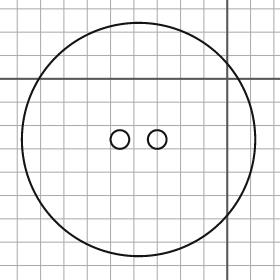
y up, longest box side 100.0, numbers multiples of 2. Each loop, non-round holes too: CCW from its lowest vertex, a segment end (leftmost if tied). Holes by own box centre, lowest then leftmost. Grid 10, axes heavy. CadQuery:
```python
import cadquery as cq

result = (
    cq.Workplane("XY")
    .moveTo(-38.0, -26.0)
    .circle(50.0)
    .moveTo(-46.0, -26.0)
    .circle(4.0)
    .moveTo(-30.0, -26.0)
    .circle(4.0)
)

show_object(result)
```